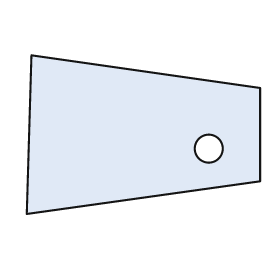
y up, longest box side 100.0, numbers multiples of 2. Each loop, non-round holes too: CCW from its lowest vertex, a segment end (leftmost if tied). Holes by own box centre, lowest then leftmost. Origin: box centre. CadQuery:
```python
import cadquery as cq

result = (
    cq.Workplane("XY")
    .moveTo(-50.0, -34.0)
    .lineTo(50.0, -20.0)
    .lineTo(50.0, 20.0)
    .lineTo(-48.0, 34.0)
    .close()
    .moveTo(28.0, -6.0)
    .circle(6.0)
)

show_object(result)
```